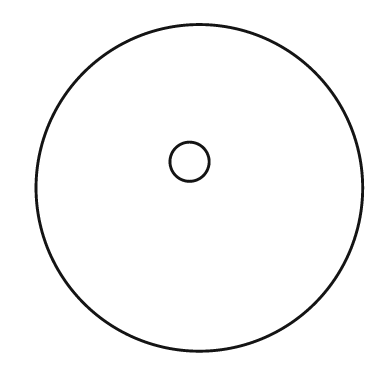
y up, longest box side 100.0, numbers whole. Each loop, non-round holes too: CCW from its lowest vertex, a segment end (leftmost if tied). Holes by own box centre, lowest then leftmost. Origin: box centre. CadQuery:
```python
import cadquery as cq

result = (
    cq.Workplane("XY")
    .moveTo(0.0, 0.0)
    .circle(50.0)
    .moveTo(-3.0, 8.0)
    .circle(6.0)
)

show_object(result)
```